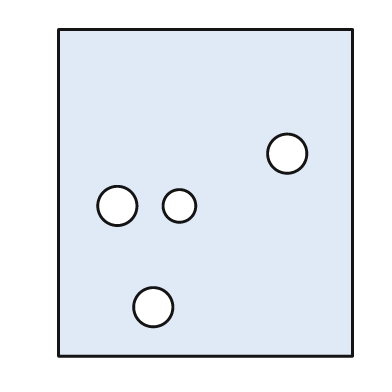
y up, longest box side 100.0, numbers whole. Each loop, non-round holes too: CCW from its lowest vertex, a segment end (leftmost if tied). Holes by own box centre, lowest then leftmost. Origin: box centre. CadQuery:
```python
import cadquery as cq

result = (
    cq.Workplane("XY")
    .moveTo(-45.0, -50.0)
    .lineTo(45.0, -50.0)
    .lineTo(45.0, 50.0)
    .lineTo(-45.0, 50.0)
    .close()
    .moveTo(-16.0, -35.0)
    .circle(6.0)
    .moveTo(-27.0, -4.0)
    .circle(6.0)
    .moveTo(-8.0, -4.0)
    .circle(5.0)
    .moveTo(25.0, 12.0)
    .circle(6.0)
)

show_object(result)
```